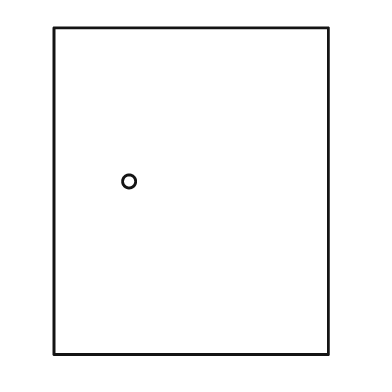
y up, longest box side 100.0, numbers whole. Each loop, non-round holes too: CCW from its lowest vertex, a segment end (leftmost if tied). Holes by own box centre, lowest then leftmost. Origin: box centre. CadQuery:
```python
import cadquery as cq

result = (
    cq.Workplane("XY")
    .moveTo(-42.0, -50.0)
    .lineTo(42.0, -50.0)
    .lineTo(42.0, 50.0)
    .lineTo(-42.0, 50.0)
    .close()
    .moveTo(-19.0, 3.0)
    .circle(2.0)
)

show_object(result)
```